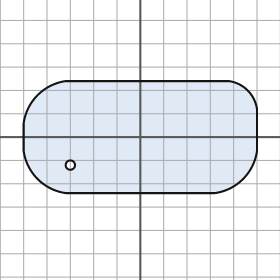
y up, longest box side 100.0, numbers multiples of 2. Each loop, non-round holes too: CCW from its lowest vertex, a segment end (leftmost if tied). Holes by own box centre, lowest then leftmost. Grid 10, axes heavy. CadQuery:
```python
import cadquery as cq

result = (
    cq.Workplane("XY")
    .moveTo(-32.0, -24.0)
    .lineTo(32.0, -24.0)
    .threePointArc((44.0, -18.0), (50.0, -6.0))
    .lineTo(50.0, 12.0)
    .threePointArc((46.0, 20.0), (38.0, 24.0))
    .lineTo(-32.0, 24.0)
    .threePointArc((-44.0, 18.0), (-50.0, 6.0))
    .lineTo(-50.0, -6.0)
    .threePointArc((-44.0, -18.0), (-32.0, -24.0))
    .close()
    .moveTo(-30.0, -12.0)
    .circle(2.0)
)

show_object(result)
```